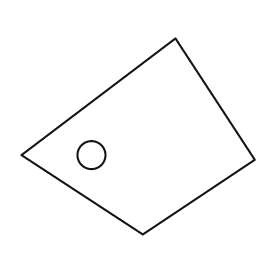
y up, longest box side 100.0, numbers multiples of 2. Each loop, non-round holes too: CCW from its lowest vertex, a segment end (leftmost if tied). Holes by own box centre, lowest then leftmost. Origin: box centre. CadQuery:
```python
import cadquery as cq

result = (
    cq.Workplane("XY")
    .moveTo(2.0, -42.0)
    .lineTo(50.0, -10.0)
    .lineTo(16.0, 42.0)
    .lineTo(-50.0, -8.0)
    .close()
    .moveTo(-20.0, -8.0)
    .circle(6.0)
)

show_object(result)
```